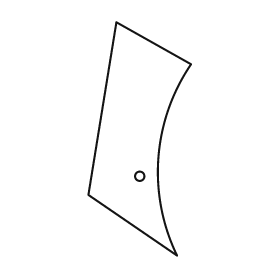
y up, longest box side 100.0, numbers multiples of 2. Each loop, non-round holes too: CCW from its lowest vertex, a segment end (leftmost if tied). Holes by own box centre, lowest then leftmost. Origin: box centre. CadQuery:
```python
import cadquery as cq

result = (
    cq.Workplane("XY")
    .moveTo(16.0, -50.0)
    .threePointArc((8.0, -8.0), (22.0, 32.0))
    .lineTo(-10.0, 50.0)
    .lineTo(-22.0, -24.0)
    .close()
    .moveTo(0.0, -16.0)
    .circle(2.0)
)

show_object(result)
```